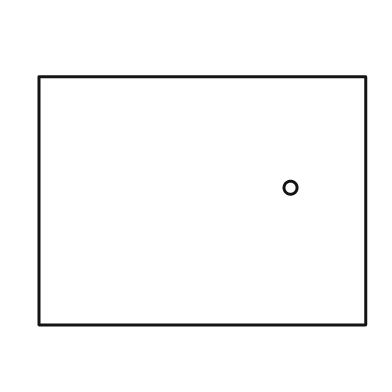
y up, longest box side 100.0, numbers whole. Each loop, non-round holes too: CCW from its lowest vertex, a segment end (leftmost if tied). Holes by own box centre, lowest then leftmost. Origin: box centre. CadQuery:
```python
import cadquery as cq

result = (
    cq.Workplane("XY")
    .moveTo(-50.0, -38.0)
    .lineTo(50.0, -38.0)
    .lineTo(50.0, 38.0)
    .lineTo(-50.0, 38.0)
    .close()
    .moveTo(27.0, 4.0)
    .circle(2.0)
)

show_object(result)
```